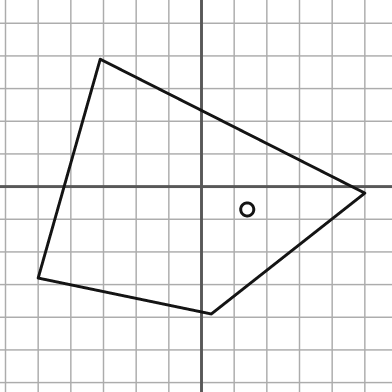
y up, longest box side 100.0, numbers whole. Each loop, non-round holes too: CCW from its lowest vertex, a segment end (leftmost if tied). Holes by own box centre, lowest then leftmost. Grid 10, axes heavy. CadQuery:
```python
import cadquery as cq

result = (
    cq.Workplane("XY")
    .moveTo(3.0, -39.0)
    .lineTo(50.0, -2.0)
    .lineTo(-31.0, 39.0)
    .lineTo(-50.0, -28.0)
    .close()
    .moveTo(14.0, -7.0)
    .circle(2.0)
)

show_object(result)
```